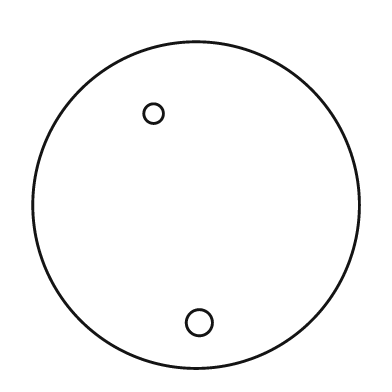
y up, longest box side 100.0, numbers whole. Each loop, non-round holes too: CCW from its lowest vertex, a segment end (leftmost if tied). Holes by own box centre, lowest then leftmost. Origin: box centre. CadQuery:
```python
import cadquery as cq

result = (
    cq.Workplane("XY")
    .moveTo(0.0, 0.0)
    .circle(50.0)
    .moveTo(1.0, -36.0)
    .circle(4.0)
    .moveTo(-13.0, 28.0)
    .circle(3.0)
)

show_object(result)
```